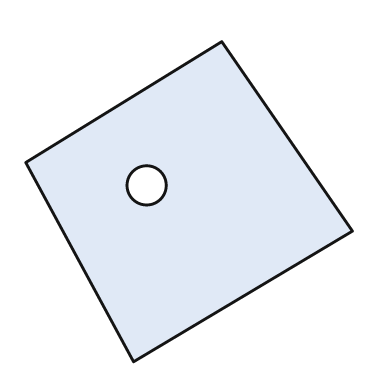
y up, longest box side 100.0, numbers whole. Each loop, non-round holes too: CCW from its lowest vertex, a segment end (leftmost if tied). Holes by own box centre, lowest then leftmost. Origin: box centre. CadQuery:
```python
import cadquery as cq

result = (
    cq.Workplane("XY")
    .moveTo(-17.0, -49.0)
    .lineTo(50.0, -9.0)
    .lineTo(10.0, 49.0)
    .lineTo(-50.0, 12.0)
    .close()
    .moveTo(-13.0, 5.0)
    .circle(6.0)
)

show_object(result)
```